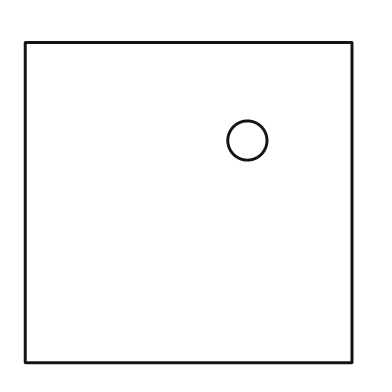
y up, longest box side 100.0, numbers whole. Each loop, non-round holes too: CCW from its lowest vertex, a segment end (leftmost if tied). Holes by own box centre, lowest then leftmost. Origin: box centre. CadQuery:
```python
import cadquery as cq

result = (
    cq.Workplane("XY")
    .moveTo(-50.0, -49.0)
    .lineTo(50.0, -49.0)
    .lineTo(50.0, 49.0)
    .lineTo(-50.0, 49.0)
    .close()
    .moveTo(18.0, 19.0)
    .circle(6.0)
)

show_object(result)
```